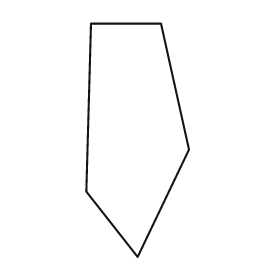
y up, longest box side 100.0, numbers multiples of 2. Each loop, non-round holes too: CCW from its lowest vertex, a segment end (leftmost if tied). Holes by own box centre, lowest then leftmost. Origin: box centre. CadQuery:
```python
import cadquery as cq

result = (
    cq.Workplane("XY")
    .moveTo(0.0, -50.0)
    .lineTo(22.0, -4.0)
    .lineTo(10.0, 50.0)
    .lineTo(-20.0, 50.0)
    .lineTo(-22.0, -22.0)
    .close()
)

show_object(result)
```